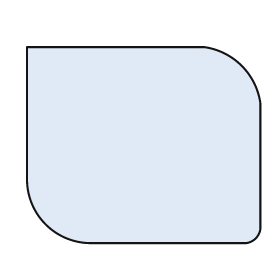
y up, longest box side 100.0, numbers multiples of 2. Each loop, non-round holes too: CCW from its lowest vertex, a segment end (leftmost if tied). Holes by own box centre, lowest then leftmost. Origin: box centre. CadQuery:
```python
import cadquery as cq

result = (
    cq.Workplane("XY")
    .moveTo(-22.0, -42.0)
    .lineTo(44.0, -42.0)
    .threePointArc((48.0, -40.0), (50.0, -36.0))
    .lineTo(50.0, 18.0)
    .threePointArc((42.0, 34.0), (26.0, 42.0))
    .lineTo(-50.0, 42.0)
    .lineTo(-50.0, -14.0)
    .threePointArc((-42.0, -34.0), (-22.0, -42.0))
    .close()
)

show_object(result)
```